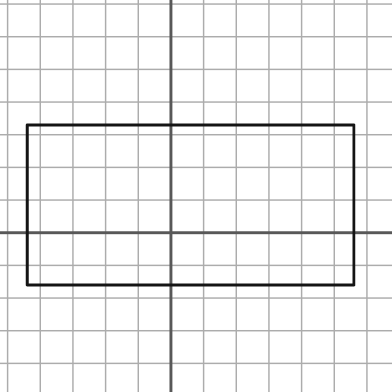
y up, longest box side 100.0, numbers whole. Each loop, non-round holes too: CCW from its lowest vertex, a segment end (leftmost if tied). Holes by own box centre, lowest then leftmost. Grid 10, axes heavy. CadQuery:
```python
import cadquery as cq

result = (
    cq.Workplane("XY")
    .moveTo(-44.0, -16.0)
    .lineTo(56.0, -16.0)
    .lineTo(56.0, 33.0)
    .lineTo(-44.0, 33.0)
    .close()
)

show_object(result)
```